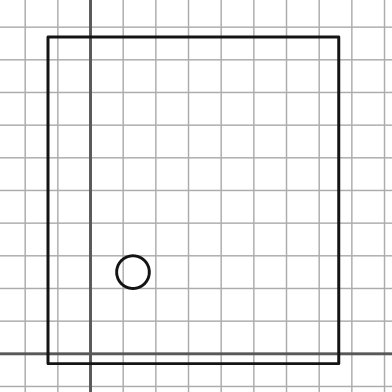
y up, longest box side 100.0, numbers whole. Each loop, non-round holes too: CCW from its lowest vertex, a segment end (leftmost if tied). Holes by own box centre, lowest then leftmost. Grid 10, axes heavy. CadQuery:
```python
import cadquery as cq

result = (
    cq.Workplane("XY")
    .moveTo(-13.0, -3.0)
    .lineTo(76.0, -3.0)
    .lineTo(76.0, 97.0)
    .lineTo(-13.0, 97.0)
    .close()
    .moveTo(13.0, 25.0)
    .circle(5.0)
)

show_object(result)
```